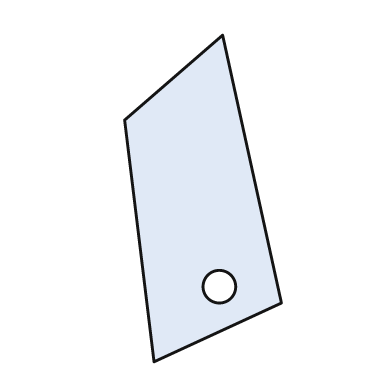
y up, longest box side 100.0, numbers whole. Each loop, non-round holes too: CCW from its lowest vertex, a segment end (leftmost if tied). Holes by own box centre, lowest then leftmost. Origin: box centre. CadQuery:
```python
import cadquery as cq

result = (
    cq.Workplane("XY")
    .moveTo(-15.0, -50.0)
    .lineTo(24.0, -32.0)
    .lineTo(6.0, 50.0)
    .lineTo(-24.0, 24.0)
    .close()
    .moveTo(5.0, -27.0)
    .circle(5.0)
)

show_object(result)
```